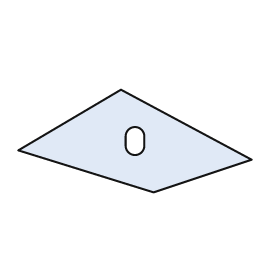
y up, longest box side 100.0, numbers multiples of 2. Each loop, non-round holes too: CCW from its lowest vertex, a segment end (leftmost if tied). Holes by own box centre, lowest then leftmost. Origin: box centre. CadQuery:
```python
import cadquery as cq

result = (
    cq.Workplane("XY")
    .moveTo(8.0, -22.0)
    .lineTo(50.0, -8.0)
    .lineTo(-6.0, 22.0)
    .lineTo(-50.0, -4.0)
    .close()
    .moveTo(-4.0, -2.0)
    .threePointArc((0.0, -6.0), (4.0, -2.0))
    .lineTo(4.0, 2.0)
    .threePointArc((0.0, 6.0), (-4.0, 2.0))
    .close()
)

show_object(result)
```